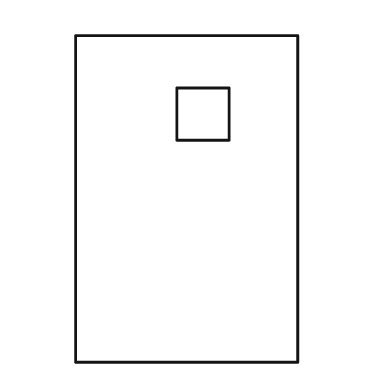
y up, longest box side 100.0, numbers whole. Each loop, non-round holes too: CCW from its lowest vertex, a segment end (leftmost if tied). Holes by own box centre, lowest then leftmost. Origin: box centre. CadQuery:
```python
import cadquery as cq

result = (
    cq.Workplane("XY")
    .moveTo(-34.0, -50.0)
    .lineTo(34.0, -50.0)
    .lineTo(34.0, 50.0)
    .lineTo(-34.0, 50.0)
    .close()
    .moveTo(-3.0, 18.0)
    .lineTo(13.0, 18.0)
    .lineTo(13.0, 34.0)
    .lineTo(-3.0, 34.0)
    .close()
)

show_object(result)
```